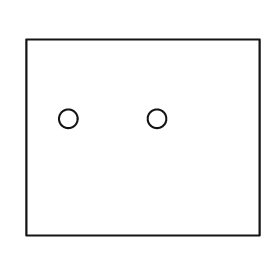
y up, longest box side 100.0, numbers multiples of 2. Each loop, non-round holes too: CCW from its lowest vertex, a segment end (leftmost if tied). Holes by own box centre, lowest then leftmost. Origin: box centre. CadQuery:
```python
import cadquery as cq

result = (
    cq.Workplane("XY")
    .moveTo(-50.0, -42.0)
    .lineTo(50.0, -42.0)
    .lineTo(50.0, 42.0)
    .lineTo(-50.0, 42.0)
    .close()
    .moveTo(-32.0, 8.0)
    .circle(4.0)
    .moveTo(6.0, 8.0)
    .circle(4.0)
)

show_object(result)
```